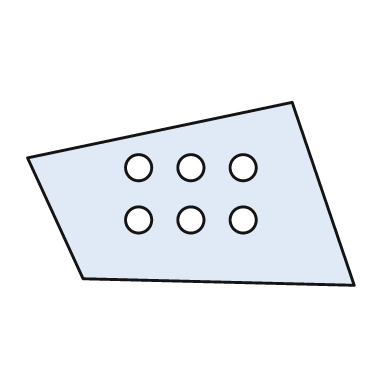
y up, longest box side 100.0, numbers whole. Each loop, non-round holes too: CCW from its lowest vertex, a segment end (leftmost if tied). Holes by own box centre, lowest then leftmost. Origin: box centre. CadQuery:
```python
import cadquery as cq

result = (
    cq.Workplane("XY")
    .moveTo(50.0, -28.0)
    .lineTo(31.0, 28.0)
    .lineTo(-50.0, 11.0)
    .lineTo(-33.0, -26.0)
    .close()
    .moveTo(-16.0, -8.0)
    .circle(4.0)
    .moveTo(0.0, -8.0)
    .circle(4.0)
    .moveTo(16.0, -8.0)
    .circle(4.0)
    .moveTo(-16.0, 8.0)
    .circle(4.0)
    .moveTo(0.0, 8.0)
    .circle(4.0)
    .moveTo(16.0, 8.0)
    .circle(4.0)
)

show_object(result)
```